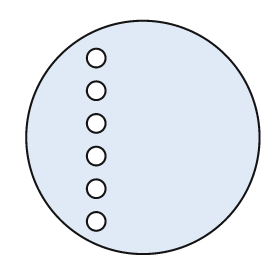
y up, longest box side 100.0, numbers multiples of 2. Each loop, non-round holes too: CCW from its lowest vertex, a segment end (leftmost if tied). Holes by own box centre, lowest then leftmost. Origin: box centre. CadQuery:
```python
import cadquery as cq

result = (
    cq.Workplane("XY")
    .moveTo(0.0, 0.0)
    .circle(50.0)
    .moveTo(-20.0, -36.0)
    .circle(4.0)
    .moveTo(-20.0, -22.0)
    .circle(4.0)
    .moveTo(-20.0, -8.0)
    .circle(4.0)
    .moveTo(-20.0, 6.0)
    .circle(4.0)
    .moveTo(-20.0, 20.0)
    .circle(4.0)
    .moveTo(-20.0, 34.0)
    .circle(4.0)
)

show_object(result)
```